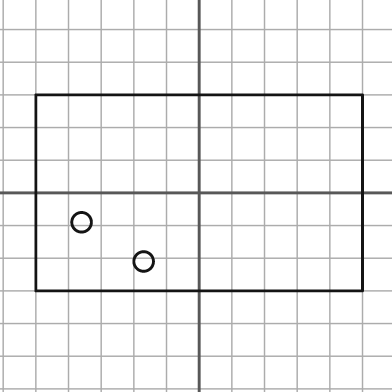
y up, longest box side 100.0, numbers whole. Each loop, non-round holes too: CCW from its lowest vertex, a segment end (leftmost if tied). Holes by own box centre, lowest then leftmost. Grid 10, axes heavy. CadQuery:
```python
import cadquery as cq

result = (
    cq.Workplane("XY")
    .moveTo(-50.0, -30.0)
    .lineTo(50.0, -30.0)
    .lineTo(50.0, 30.0)
    .lineTo(-50.0, 30.0)
    .close()
    .moveTo(-17.0, -21.0)
    .circle(3.0)
    .moveTo(-36.0, -9.0)
    .circle(3.0)
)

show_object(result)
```